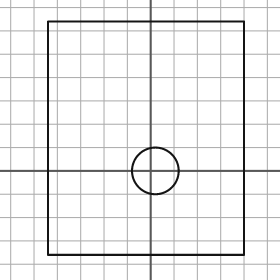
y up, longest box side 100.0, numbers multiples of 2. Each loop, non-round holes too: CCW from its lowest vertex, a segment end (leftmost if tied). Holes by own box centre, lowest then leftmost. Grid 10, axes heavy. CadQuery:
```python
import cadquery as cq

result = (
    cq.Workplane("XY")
    .moveTo(-44.0, -36.0)
    .lineTo(40.0, -36.0)
    .lineTo(40.0, 64.0)
    .lineTo(-44.0, 64.0)
    .close()
    .moveTo(2.0, 0.0)
    .circle(10.0)
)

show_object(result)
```